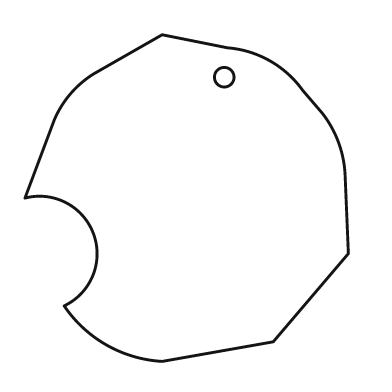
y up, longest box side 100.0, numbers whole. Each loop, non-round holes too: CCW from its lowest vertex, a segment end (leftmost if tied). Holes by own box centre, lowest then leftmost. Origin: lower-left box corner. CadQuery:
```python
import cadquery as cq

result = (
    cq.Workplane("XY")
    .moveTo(42.0, 0.0)
    .lineTo(76.0, 6.0)
    .lineTo(99.0, 33.0)
    .lineTo(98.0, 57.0)
    .threePointArc((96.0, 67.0), (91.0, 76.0))
    .lineTo(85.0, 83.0)
    .threePointArc((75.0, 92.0), (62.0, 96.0))
    .lineTo(42.0, 100.0)
    .lineTo(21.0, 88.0)
    .threePointArc((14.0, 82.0), (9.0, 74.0))
    .lineTo(0.0, 50.0)
    .threePointArc((21.0, 39.0), (12.0, 17.0))
    .threePointArc((25.0, 5.0), (42.0, 0.0))
    .close()
    .moveTo(61.0, 87.0)
    .circle(3.0)
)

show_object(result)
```